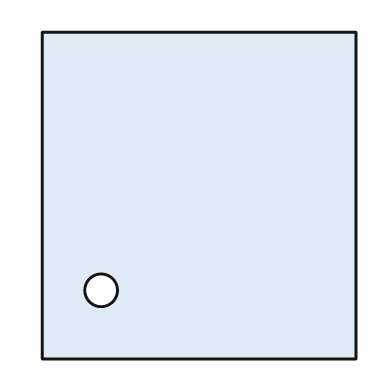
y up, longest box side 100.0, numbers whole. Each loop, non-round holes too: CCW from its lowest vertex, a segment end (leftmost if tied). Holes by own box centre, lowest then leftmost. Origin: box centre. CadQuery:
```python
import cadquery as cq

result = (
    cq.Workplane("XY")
    .moveTo(-48.0, -50.0)
    .lineTo(48.0, -50.0)
    .lineTo(48.0, 50.0)
    .lineTo(-48.0, 50.0)
    .close()
    .moveTo(-30.0, -29.0)
    .circle(5.0)
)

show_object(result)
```